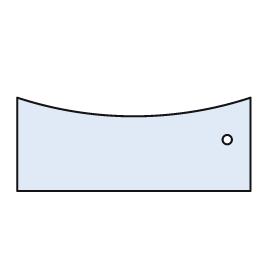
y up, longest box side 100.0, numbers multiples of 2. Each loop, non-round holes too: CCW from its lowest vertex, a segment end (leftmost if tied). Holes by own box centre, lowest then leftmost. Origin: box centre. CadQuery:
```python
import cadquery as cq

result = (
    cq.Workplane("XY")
    .moveTo(-50.0, -20.0)
    .lineTo(50.0, -20.0)
    .lineTo(50.0, 20.0)
    .threePointArc((0.0, 12.0), (-50.0, 20.0))
    .close()
    .moveTo(40.0, 2.0)
    .circle(2.0)
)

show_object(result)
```